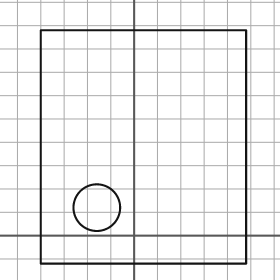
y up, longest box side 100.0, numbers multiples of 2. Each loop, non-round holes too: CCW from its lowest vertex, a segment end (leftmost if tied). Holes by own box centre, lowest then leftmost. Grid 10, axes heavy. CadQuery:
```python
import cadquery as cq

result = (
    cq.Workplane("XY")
    .moveTo(-40.0, -12.0)
    .lineTo(48.0, -12.0)
    .lineTo(48.0, 88.0)
    .lineTo(-40.0, 88.0)
    .close()
    .moveTo(-16.0, 12.0)
    .circle(10.0)
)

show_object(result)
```